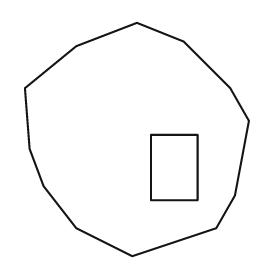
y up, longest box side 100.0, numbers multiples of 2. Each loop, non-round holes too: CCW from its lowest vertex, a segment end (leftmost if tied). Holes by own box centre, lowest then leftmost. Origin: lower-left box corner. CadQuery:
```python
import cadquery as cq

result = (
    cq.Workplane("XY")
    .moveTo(46.0, 0.0)
    .lineTo(82.0, 12.0)
    .lineTo(90.0, 26.0)
    .lineTo(96.0, 58.0)
    .lineTo(88.0, 72.0)
    .lineTo(68.0, 92.0)
    .lineTo(48.0, 100.0)
    .lineTo(22.0, 90.0)
    .lineTo(0.0, 72.0)
    .lineTo(2.0, 46.0)
    .lineTo(8.0, 30.0)
    .lineTo(22.0, 12.0)
    .close()
    .moveTo(54.0, 24.0)
    .lineTo(74.0, 24.0)
    .lineTo(74.0, 52.0)
    .lineTo(54.0, 52.0)
    .close()
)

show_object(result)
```